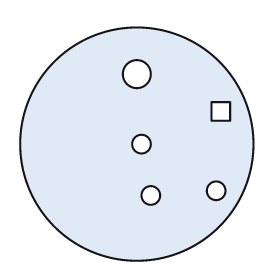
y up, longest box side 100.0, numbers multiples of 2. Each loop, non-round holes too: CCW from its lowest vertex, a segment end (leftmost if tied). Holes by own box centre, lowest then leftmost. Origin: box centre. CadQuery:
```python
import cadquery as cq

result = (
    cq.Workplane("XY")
    .moveTo(0.0, 0.0)
    .circle(50.0)
    .moveTo(6.0, -22.0)
    .circle(4.0)
    .moveTo(34.0, -20.0)
    .circle(4.0)
    .moveTo(2.0, 0.0)
    .circle(4.0)
    .moveTo(32.0, 10.0)
    .lineTo(40.0, 10.0)
    .lineTo(40.0, 18.0)
    .lineTo(32.0, 18.0)
    .close()
    .moveTo(0.0, 30.0)
    .circle(6.0)
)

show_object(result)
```